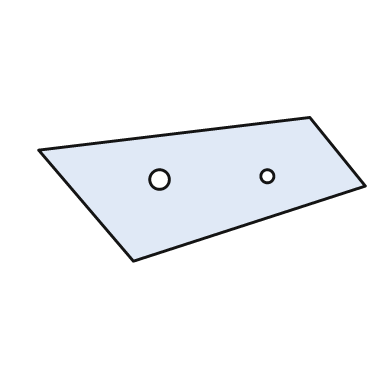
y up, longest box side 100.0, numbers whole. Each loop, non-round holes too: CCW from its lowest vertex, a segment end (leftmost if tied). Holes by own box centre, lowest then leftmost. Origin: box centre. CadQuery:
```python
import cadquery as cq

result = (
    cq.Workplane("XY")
    .moveTo(-21.0, -22.0)
    .lineTo(50.0, 1.0)
    .lineTo(33.0, 22.0)
    .lineTo(-50.0, 12.0)
    .close()
    .moveTo(-13.0, 3.0)
    .circle(3.0)
    .moveTo(20.0, 4.0)
    .circle(2.0)
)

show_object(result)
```